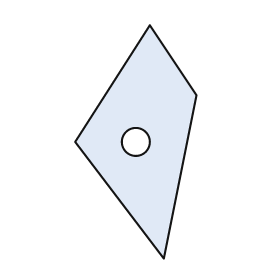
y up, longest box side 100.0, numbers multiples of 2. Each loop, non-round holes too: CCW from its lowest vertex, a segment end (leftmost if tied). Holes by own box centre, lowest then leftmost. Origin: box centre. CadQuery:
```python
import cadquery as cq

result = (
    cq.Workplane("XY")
    .moveTo(12.0, -50.0)
    .lineTo(26.0, 20.0)
    .lineTo(6.0, 50.0)
    .lineTo(-26.0, 0.0)
    .close()
    .moveTo(0.0, 0.0)
    .circle(6.0)
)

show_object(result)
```